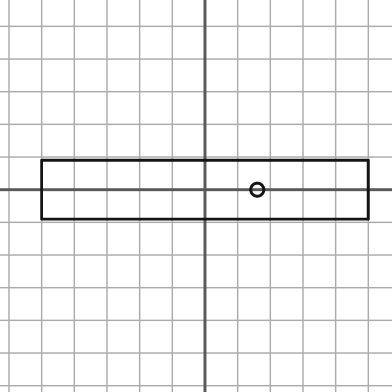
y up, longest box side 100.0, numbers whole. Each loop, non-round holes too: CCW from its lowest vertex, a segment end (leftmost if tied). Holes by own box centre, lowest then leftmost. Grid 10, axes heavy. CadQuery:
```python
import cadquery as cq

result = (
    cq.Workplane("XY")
    .moveTo(-50.0, -9.0)
    .lineTo(50.0, -9.0)
    .lineTo(50.0, 9.0)
    .lineTo(-50.0, 9.0)
    .close()
    .moveTo(16.0, 0.0)
    .circle(2.0)
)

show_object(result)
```